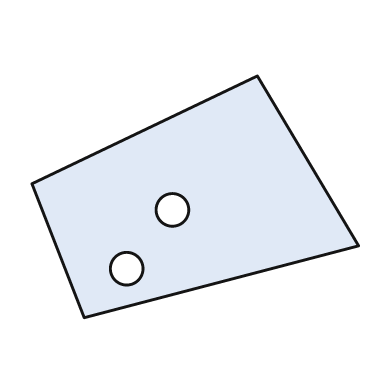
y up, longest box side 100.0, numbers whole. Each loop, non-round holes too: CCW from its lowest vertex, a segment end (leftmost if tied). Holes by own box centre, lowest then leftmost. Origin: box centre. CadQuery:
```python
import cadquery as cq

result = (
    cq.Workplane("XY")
    .moveTo(-34.0, -37.0)
    .lineTo(50.0, -15.0)
    .lineTo(19.0, 37.0)
    .lineTo(-50.0, 4.0)
    .close()
    .moveTo(-21.0, -22.0)
    .circle(5.0)
    .moveTo(-7.0, -4.0)
    .circle(5.0)
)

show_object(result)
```